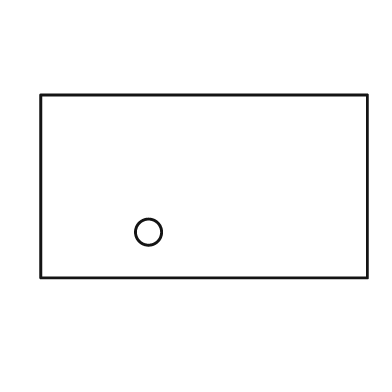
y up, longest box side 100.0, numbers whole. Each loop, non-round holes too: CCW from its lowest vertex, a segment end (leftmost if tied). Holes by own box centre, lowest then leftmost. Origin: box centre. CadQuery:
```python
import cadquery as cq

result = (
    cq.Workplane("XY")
    .moveTo(-50.0, -28.0)
    .lineTo(50.0, -28.0)
    .lineTo(50.0, 28.0)
    .lineTo(-50.0, 28.0)
    .close()
    .moveTo(-17.0, -14.0)
    .circle(4.0)
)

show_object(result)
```